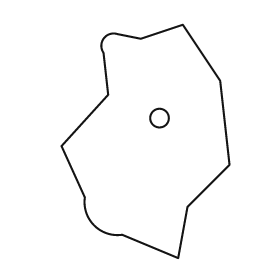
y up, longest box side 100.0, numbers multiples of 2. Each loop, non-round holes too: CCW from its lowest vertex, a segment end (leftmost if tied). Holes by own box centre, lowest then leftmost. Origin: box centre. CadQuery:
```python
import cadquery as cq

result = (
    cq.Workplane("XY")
    .moveTo(14.0, -50.0)
    .lineTo(18.0, -28.0)
    .lineTo(36.0, -10.0)
    .lineTo(32.0, 26.0)
    .lineTo(16.0, 50.0)
    .lineTo(-2.0, 44.0)
    .lineTo(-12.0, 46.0)
    .threePointArc((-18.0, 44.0), (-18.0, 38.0))
    .lineTo(-16.0, 20.0)
    .lineTo(-36.0, -2.0)
    .lineTo(-26.0, -24.0)
    .threePointArc((-22.0, -36.0), (-10.0, -40.0))
    .close()
    .moveTo(6.0, 10.0)
    .circle(4.0)
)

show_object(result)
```